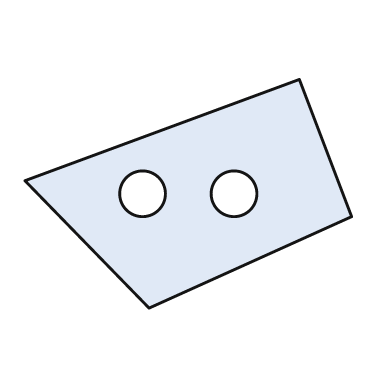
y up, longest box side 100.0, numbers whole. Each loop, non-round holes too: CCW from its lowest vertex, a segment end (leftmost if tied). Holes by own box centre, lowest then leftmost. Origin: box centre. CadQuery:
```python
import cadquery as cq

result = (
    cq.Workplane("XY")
    .moveTo(-12.0, -35.0)
    .lineTo(50.0, -7.0)
    .lineTo(34.0, 35.0)
    .lineTo(-50.0, 4.0)
    .close()
    .moveTo(-14.0, 0.0)
    .circle(7.0)
    .moveTo(14.0, 0.0)
    .circle(7.0)
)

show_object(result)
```